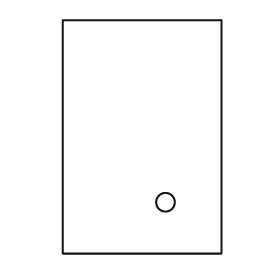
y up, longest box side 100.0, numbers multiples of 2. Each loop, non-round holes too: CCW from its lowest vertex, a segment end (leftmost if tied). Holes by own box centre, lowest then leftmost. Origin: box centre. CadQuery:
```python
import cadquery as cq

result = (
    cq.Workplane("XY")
    .moveTo(-34.0, -50.0)
    .lineTo(34.0, -50.0)
    .lineTo(34.0, 50.0)
    .lineTo(-34.0, 50.0)
    .close()
    .moveTo(10.0, -28.0)
    .circle(4.0)
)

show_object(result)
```